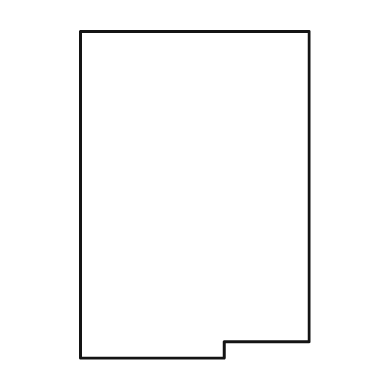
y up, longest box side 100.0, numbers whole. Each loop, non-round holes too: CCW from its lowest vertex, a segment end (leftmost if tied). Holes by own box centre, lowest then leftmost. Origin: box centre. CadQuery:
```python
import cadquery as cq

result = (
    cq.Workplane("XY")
    .moveTo(-35.0, -50.0)
    .lineTo(9.0, -50.0)
    .lineTo(9.0, -45.0)
    .lineTo(35.0, -45.0)
    .lineTo(35.0, 50.0)
    .lineTo(-35.0, 50.0)
    .close()
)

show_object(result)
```